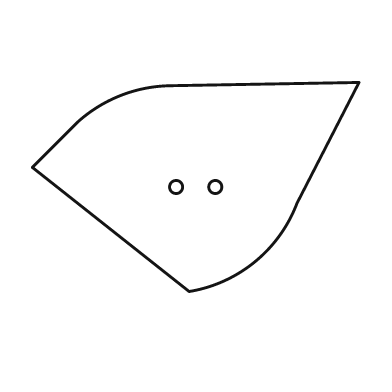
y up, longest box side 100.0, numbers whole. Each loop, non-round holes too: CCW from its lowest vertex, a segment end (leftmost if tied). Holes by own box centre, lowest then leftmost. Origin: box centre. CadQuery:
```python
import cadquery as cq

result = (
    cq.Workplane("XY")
    .moveTo(-2.0, -32.0)
    .threePointArc((18.0, -23.0), (31.0, -5.0))
    .lineTo(50.0, 32.0)
    .lineTo(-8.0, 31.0)
    .threePointArc((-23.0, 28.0), (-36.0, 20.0))
    .lineTo(-50.0, 6.0)
    .close()
    .moveTo(-6.0, 0.0)
    .circle(2.0)
    .moveTo(6.0, 0.0)
    .circle(2.0)
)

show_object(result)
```